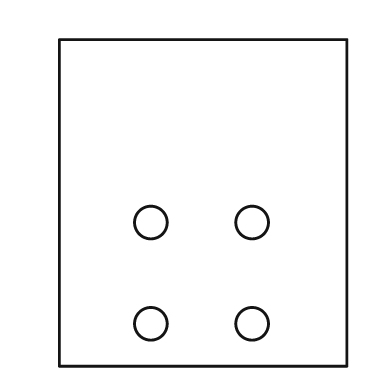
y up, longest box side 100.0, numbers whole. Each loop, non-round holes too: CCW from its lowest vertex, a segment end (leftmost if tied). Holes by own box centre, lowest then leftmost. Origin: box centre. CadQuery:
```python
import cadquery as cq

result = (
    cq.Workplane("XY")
    .moveTo(-44.0, -50.0)
    .lineTo(44.0, -50.0)
    .lineTo(44.0, 50.0)
    .lineTo(-44.0, 50.0)
    .close()
    .moveTo(-16.0, -37.0)
    .circle(5.0)
    .moveTo(15.0, -37.0)
    .circle(5.0)
    .moveTo(-16.0, -6.0)
    .circle(5.0)
    .moveTo(15.0, -6.0)
    .circle(5.0)
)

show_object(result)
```